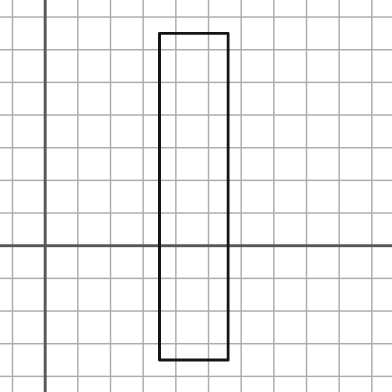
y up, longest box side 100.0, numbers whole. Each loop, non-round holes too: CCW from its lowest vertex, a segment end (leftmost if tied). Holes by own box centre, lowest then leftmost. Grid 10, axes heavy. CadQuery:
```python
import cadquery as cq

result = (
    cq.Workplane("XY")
    .moveTo(35.0, -35.0)
    .lineTo(56.0, -35.0)
    .lineTo(56.0, 65.0)
    .lineTo(35.0, 65.0)
    .close()
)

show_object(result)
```